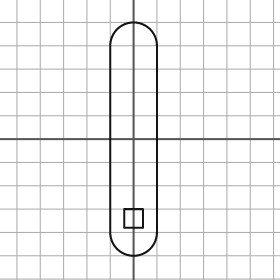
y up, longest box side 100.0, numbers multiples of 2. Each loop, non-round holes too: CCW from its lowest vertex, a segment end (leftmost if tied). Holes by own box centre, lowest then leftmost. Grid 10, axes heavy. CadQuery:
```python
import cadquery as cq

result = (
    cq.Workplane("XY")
    .moveTo(-10.0, -40.0)
    .threePointArc((0.0, -50.0), (10.0, -40.0))
    .lineTo(10.0, 40.0)
    .threePointArc((0.0, 50.0), (-10.0, 40.0))
    .close()
    .moveTo(-4.0, -38.0)
    .lineTo(4.0, -38.0)
    .lineTo(4.0, -30.0)
    .lineTo(-4.0, -30.0)
    .close()
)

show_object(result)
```